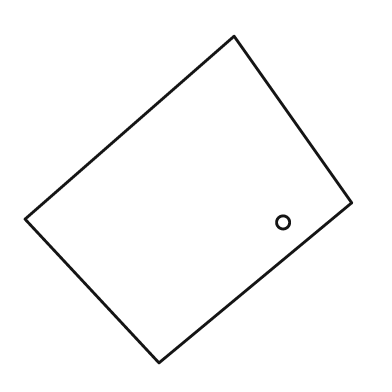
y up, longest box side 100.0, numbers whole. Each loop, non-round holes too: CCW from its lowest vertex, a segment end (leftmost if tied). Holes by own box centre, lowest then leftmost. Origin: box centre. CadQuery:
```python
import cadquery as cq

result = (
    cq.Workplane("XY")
    .moveTo(-9.0, -50.0)
    .lineTo(50.0, -1.0)
    .lineTo(14.0, 50.0)
    .lineTo(-50.0, -6.0)
    .close()
    .moveTo(29.0, -7.0)
    .circle(2.0)
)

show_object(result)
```